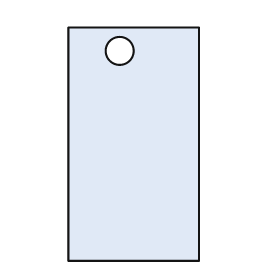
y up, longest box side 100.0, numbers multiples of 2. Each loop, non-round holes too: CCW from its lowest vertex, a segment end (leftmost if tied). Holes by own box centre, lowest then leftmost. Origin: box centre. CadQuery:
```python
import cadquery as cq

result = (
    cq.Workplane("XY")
    .moveTo(-28.0, -50.0)
    .lineTo(28.0, -50.0)
    .lineTo(28.0, 50.0)
    .lineTo(-28.0, 50.0)
    .close()
    .moveTo(-6.0, 40.0)
    .circle(6.0)
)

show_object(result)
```